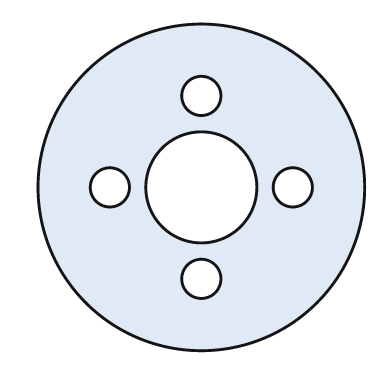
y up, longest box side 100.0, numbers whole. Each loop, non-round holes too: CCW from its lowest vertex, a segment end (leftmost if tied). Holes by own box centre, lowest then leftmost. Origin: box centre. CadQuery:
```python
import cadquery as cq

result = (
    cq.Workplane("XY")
    .moveTo(0.0, 0.0)
    .circle(50.0)
    .moveTo(0.0, -28.0)
    .circle(6.0)
    .moveTo(-28.0, 0.0)
    .circle(6.0)
    .moveTo(0.0, 0.0)
    .circle(17.0)
    .moveTo(28.0, 0.0)
    .circle(6.0)
    .moveTo(0.0, 28.0)
    .circle(6.0)
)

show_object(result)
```